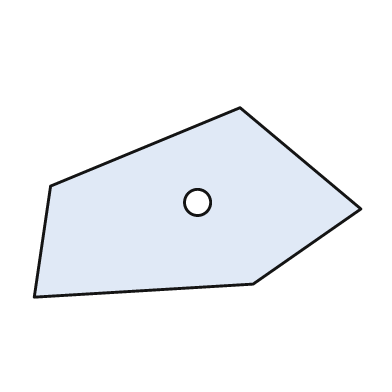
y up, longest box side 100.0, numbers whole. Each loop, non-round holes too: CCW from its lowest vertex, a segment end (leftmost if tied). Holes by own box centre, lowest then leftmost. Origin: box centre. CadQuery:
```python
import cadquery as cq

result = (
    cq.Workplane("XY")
    .moveTo(-50.0, -29.0)
    .lineTo(17.0, -25.0)
    .lineTo(50.0, -2.0)
    .lineTo(13.0, 29.0)
    .lineTo(-45.0, 5.0)
    .close()
    .moveTo(0.0, 0.0)
    .circle(4.0)
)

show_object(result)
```